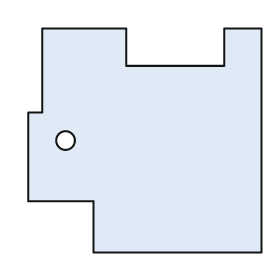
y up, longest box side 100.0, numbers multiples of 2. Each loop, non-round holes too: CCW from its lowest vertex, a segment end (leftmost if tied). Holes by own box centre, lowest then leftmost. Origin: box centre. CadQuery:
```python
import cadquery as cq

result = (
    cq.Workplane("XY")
    .moveTo(-22.0, -48.0)
    .lineTo(50.0, -48.0)
    .lineTo(50.0, 48.0)
    .lineTo(34.0, 48.0)
    .lineTo(34.0, 32.0)
    .lineTo(-8.0, 32.0)
    .lineTo(-8.0, 48.0)
    .lineTo(-44.0, 48.0)
    .lineTo(-44.0, 12.0)
    .lineTo(-50.0, 12.0)
    .lineTo(-50.0, -26.0)
    .lineTo(-22.0, -26.0)
    .close()
    .moveTo(-34.0, 0.0)
    .circle(4.0)
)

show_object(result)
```